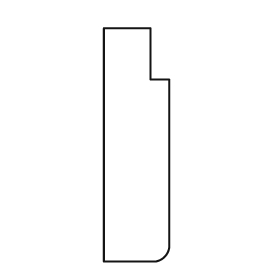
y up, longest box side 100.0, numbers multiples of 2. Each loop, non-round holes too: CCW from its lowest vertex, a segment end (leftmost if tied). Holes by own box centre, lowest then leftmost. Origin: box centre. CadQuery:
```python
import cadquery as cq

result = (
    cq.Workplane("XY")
    .moveTo(-14.0, -50.0)
    .lineTo(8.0, -50.0)
    .threePointArc((12.0, -48.0), (14.0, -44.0))
    .lineTo(14.0, 28.0)
    .lineTo(6.0, 28.0)
    .lineTo(6.0, 50.0)
    .lineTo(-14.0, 50.0)
    .close()
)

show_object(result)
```